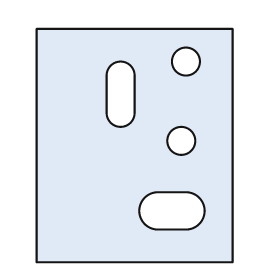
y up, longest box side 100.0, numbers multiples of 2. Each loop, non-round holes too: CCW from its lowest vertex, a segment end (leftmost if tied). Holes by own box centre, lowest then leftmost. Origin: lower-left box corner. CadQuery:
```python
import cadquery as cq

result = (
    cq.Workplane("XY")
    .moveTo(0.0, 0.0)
    .lineTo(84.0, 0.0)
    .lineTo(84.0, 100.0)
    .lineTo(0.0, 100.0)
    .close()
    .moveTo(52.0, 14.0)
    .lineTo(64.0, 14.0)
    .threePointArc((72.0, 22.0), (64.0, 30.0))
    .lineTo(52.0, 30.0)
    .threePointArc((44.0, 22.0), (52.0, 14.0))
    .close()
    .moveTo(62.0, 52.0)
    .circle(6.0)
    .moveTo(30.0, 64.0)
    .threePointArc((36.0, 58.0), (42.0, 64.0))
    .lineTo(42.0, 80.0)
    .threePointArc((36.0, 86.0), (30.0, 80.0))
    .close()
    .moveTo(64.0, 86.0)
    .circle(6.0)
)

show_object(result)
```